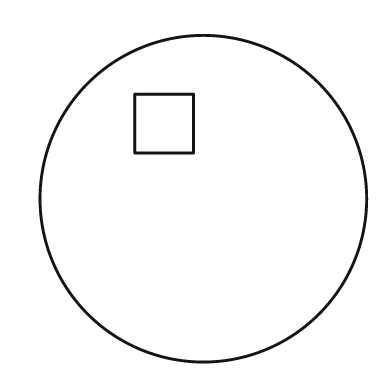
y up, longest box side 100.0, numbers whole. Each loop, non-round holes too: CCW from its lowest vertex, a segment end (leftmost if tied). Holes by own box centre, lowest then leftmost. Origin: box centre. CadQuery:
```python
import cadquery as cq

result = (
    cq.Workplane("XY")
    .moveTo(0.0, 0.0)
    .circle(50.0)
    .moveTo(-21.0, 14.0)
    .lineTo(-3.0, 14.0)
    .lineTo(-3.0, 32.0)
    .lineTo(-21.0, 32.0)
    .close()
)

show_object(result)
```